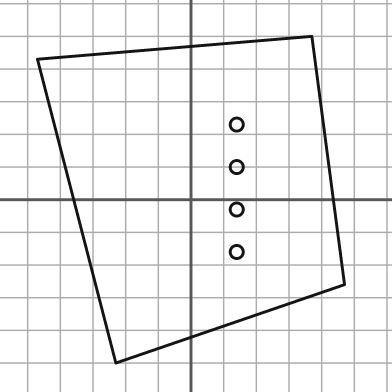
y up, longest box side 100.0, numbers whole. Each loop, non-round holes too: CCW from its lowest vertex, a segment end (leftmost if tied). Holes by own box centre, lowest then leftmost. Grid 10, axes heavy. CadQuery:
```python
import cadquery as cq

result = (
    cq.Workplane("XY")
    .moveTo(-23.0, -50.0)
    .lineTo(47.0, -26.0)
    .lineTo(37.0, 50.0)
    .lineTo(-47.0, 43.0)
    .close()
    .moveTo(14.0, -16.0)
    .circle(2.0)
    .moveTo(14.0, -3.0)
    .circle(2.0)
    .moveTo(14.0, 10.0)
    .circle(2.0)
    .moveTo(14.0, 23.0)
    .circle(2.0)
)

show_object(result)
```